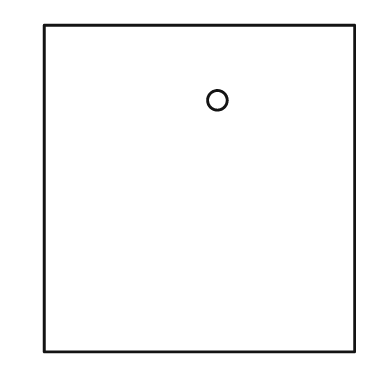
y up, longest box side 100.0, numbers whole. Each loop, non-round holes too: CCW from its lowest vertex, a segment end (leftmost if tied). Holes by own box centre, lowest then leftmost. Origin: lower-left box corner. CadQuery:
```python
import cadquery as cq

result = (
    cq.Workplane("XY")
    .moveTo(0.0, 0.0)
    .lineTo(95.0, 0.0)
    .lineTo(95.0, 100.0)
    .lineTo(0.0, 100.0)
    .close()
    .moveTo(53.0, 77.0)
    .circle(3.0)
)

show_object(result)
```